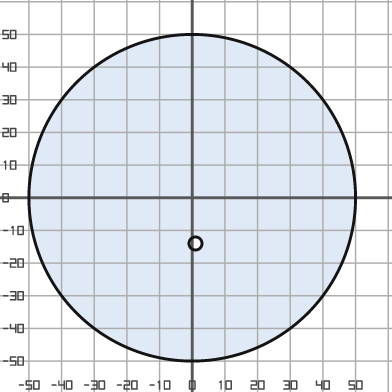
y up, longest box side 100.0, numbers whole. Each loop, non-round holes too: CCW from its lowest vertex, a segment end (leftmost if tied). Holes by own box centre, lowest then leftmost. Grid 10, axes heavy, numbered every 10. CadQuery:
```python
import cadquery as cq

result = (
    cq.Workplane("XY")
    .moveTo(0.0, 0.0)
    .circle(50.0)
    .moveTo(1.0, -14.0)
    .circle(2.0)
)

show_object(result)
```